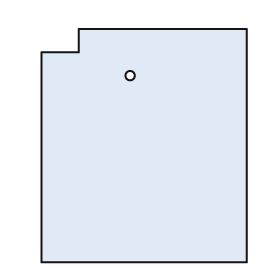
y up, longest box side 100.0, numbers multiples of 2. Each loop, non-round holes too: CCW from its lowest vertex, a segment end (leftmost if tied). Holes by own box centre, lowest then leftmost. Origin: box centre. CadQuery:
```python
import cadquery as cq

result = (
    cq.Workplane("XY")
    .moveTo(-44.0, -50.0)
    .lineTo(44.0, -50.0)
    .lineTo(44.0, 50.0)
    .lineTo(-28.0, 50.0)
    .lineTo(-28.0, 40.0)
    .lineTo(-44.0, 40.0)
    .close()
    .moveTo(-6.0, 30.0)
    .circle(2.0)
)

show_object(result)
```